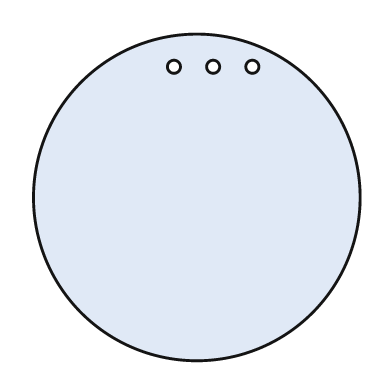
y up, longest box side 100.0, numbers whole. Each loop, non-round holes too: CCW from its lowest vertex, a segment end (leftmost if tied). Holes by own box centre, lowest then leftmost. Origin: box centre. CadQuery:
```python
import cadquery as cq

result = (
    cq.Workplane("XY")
    .moveTo(0.0, 0.0)
    .circle(50.0)
    .moveTo(-7.0, 40.0)
    .circle(2.0)
    .moveTo(5.0, 40.0)
    .circle(2.0)
    .moveTo(17.0, 40.0)
    .circle(2.0)
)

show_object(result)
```